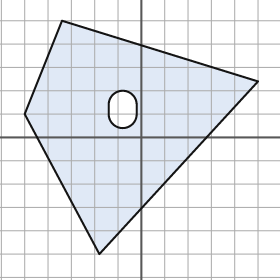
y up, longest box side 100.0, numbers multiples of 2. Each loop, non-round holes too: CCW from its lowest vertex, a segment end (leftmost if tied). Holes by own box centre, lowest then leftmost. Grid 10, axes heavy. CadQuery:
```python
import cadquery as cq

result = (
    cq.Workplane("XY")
    .moveTo(-18.0, -50.0)
    .lineTo(50.0, 24.0)
    .lineTo(-34.0, 50.0)
    .lineTo(-50.0, 10.0)
    .close()
    .moveTo(-14.0, 10.0)
    .threePointArc((-8.0, 4.0), (-2.0, 10.0))
    .lineTo(-2.0, 14.0)
    .threePointArc((-8.0, 20.0), (-14.0, 14.0))
    .close()
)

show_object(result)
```